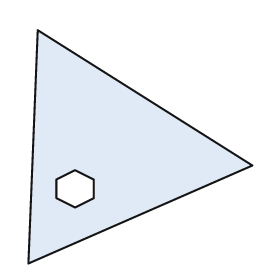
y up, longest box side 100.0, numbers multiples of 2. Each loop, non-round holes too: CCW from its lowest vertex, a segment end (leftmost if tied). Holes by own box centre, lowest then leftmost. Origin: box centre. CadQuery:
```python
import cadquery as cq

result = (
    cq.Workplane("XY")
    .moveTo(-48.0, -50.0)
    .lineTo(48.0, -8.0)
    .lineTo(-44.0, 50.0)
    .close()
    .moveTo(-28.0, -26.0)
    .lineTo(-20.0, -22.0)
    .lineTo(-20.0, -14.0)
    .lineTo(-28.0, -10.0)
    .lineTo(-36.0, -14.0)
    .lineTo(-36.0, -22.0)
    .close()
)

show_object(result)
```